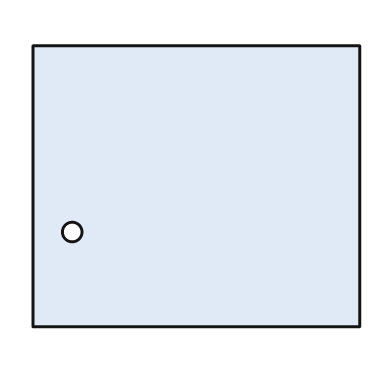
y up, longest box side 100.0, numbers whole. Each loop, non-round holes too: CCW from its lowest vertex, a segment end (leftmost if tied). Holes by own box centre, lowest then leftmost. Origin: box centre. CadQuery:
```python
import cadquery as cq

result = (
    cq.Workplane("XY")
    .moveTo(-50.0, -43.0)
    .lineTo(50.0, -43.0)
    .lineTo(50.0, 43.0)
    .lineTo(-50.0, 43.0)
    .close()
    .moveTo(-38.0, -14.0)
    .circle(3.0)
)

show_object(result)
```